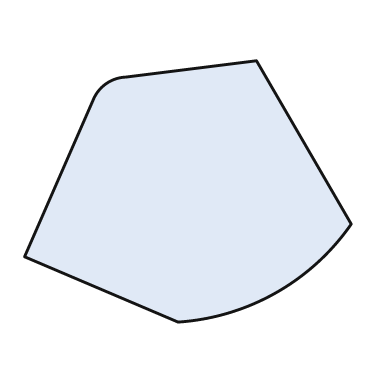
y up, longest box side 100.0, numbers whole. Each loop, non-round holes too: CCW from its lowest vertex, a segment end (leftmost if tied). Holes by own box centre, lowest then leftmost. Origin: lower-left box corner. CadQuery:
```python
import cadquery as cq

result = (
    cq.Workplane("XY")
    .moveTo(47.0, 0.0)
    .threePointArc((77.0, 9.0), (100.0, 30.0))
    .lineTo(71.0, 80.0)
    .lineTo(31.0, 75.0)
    .threePointArc((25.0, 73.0), (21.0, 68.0))
    .lineTo(0.0, 20.0)
    .close()
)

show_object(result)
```